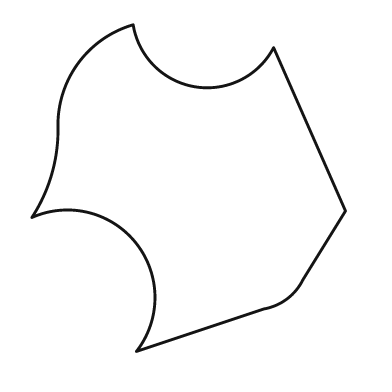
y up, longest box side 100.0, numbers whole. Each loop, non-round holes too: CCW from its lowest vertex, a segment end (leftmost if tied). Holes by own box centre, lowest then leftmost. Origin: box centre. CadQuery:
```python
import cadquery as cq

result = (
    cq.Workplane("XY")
    .moveTo(-16.0, -50.0)
    .lineTo(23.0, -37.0)
    .threePointArc((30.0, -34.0), (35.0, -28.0))
    .lineTo(48.0, -7.0)
    .lineTo(26.0, 43.0)
    .threePointArc((2.0, 31.0), (-17.0, 50.0))
    .threePointArc((-34.0, 38.0), (-40.0, 18.0))
    .threePointArc((-42.0, 4.0), (-48.0, -9.0))
    .threePointArc((-16.0, -17.0), (-16.0, -50.0))
    .close()
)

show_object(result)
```